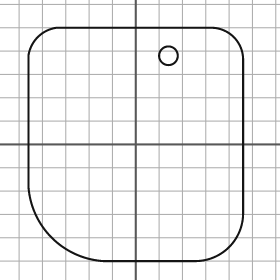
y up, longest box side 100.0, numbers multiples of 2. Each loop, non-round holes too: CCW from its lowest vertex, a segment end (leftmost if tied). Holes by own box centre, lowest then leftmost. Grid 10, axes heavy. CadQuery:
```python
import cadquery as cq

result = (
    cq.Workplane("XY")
    .moveTo(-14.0, -50.0)
    .lineTo(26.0, -50.0)
    .threePointArc((40.0, -44.0), (46.0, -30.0))
    .lineTo(46.0, 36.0)
    .threePointArc((42.0, 46.0), (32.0, 50.0))
    .lineTo(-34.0, 50.0)
    .threePointArc((-42.0, 46.0), (-46.0, 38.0))
    .lineTo(-46.0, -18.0)
    .threePointArc((-36.0, -40.0), (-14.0, -50.0))
    .close()
    .moveTo(14.0, 38.0)
    .circle(4.0)
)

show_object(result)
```